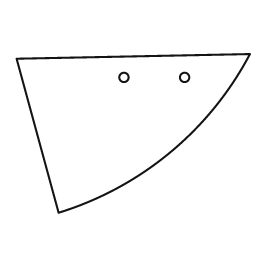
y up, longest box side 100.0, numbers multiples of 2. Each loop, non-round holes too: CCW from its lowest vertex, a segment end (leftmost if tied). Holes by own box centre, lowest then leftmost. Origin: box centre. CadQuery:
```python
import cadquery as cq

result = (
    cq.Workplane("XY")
    .moveTo(-32.0, -34.0)
    .threePointArc((16.0, -8.0), (50.0, 34.0))
    .lineTo(-50.0, 32.0)
    .close()
    .moveTo(-4.0, 24.0)
    .circle(2.0)
    .moveTo(22.0, 24.0)
    .circle(2.0)
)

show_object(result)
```